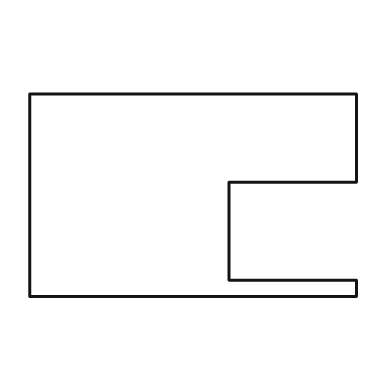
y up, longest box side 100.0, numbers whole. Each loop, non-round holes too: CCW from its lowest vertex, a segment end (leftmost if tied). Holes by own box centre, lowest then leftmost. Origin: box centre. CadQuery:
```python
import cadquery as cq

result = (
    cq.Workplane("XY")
    .moveTo(-50.0, -31.0)
    .lineTo(50.0, -31.0)
    .lineTo(50.0, -26.0)
    .lineTo(11.0, -26.0)
    .lineTo(11.0, 4.0)
    .lineTo(50.0, 4.0)
    .lineTo(50.0, 31.0)
    .lineTo(-50.0, 31.0)
    .close()
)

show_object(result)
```